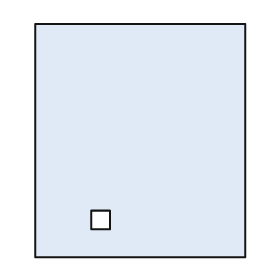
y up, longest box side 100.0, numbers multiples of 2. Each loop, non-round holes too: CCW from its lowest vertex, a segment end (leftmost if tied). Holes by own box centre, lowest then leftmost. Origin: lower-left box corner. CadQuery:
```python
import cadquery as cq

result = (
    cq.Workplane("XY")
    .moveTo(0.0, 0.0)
    .lineTo(90.0, 0.0)
    .lineTo(90.0, 100.0)
    .lineTo(0.0, 100.0)
    .close()
    .moveTo(24.0, 12.0)
    .lineTo(32.0, 12.0)
    .lineTo(32.0, 20.0)
    .lineTo(24.0, 20.0)
    .close()
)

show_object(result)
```